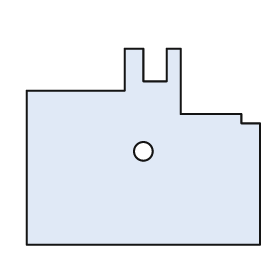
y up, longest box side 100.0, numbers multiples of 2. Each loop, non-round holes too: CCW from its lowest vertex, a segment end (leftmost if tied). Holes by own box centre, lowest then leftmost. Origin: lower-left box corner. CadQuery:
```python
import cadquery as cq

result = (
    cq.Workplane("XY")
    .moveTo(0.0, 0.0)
    .lineTo(100.0, 0.0)
    .lineTo(100.0, 52.0)
    .lineTo(92.0, 52.0)
    .lineTo(92.0, 56.0)
    .lineTo(66.0, 56.0)
    .lineTo(66.0, 84.0)
    .lineTo(60.0, 84.0)
    .lineTo(60.0, 70.0)
    .lineTo(50.0, 70.0)
    .lineTo(50.0, 84.0)
    .lineTo(42.0, 84.0)
    .lineTo(42.0, 66.0)
    .lineTo(0.0, 66.0)
    .close()
    .moveTo(50.0, 40.0)
    .circle(4.0)
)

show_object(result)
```